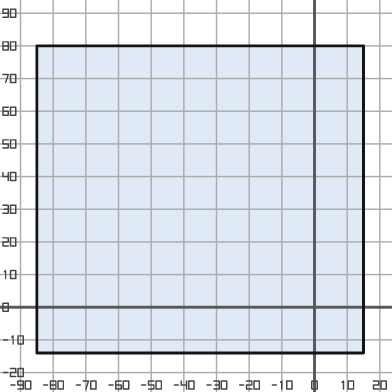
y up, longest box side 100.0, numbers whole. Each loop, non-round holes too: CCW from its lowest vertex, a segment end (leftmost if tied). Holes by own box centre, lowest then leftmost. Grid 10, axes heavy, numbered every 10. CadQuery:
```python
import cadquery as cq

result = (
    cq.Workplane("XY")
    .moveTo(-85.0, -14.0)
    .lineTo(15.0, -14.0)
    .lineTo(15.0, 80.0)
    .lineTo(-85.0, 80.0)
    .close()
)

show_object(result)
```